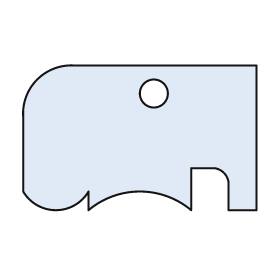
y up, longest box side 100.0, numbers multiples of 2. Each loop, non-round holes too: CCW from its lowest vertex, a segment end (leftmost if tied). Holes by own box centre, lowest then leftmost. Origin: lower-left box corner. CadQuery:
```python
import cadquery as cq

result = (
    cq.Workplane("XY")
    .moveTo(28.0, 0.0)
    .threePointArc((50.0, 8.0), (72.0, 0.0))
    .lineTo(72.0, 18.0)
    .lineTo(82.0, 18.0)
    .threePointArc((86.0, 16.0), (88.0, 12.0))
    .lineTo(88.0, 0.0)
    .lineTo(100.0, 0.0)
    .lineTo(100.0, 62.0)
    .lineTo(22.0, 62.0)
    .threePointArc((6.0, 56.0), (0.0, 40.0))
    .lineTo(0.0, 8.0)
    .threePointArc((14.0, 0.0), (28.0, 8.0))
    .close()
    .moveTo(56.0, 50.0)
    .circle(6.0)
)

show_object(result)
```